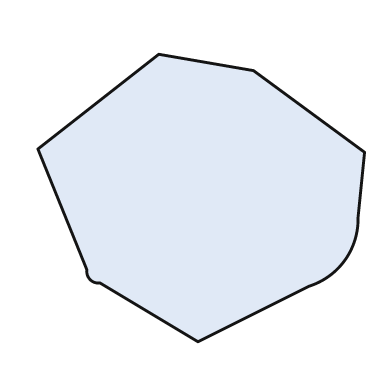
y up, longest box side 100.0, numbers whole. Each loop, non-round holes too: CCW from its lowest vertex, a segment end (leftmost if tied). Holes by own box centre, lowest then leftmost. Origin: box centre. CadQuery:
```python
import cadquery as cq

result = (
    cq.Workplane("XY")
    .moveTo(-1.0, -44.0)
    .lineTo(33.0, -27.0)
    .threePointArc((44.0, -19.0), (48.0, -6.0))
    .lineTo(50.0, 14.0)
    .lineTo(16.0, 39.0)
    .lineTo(-13.0, 44.0)
    .lineTo(-50.0, 15.0)
    .lineTo(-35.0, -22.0)
    .threePointArc((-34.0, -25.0), (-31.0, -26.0))
    .close()
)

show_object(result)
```